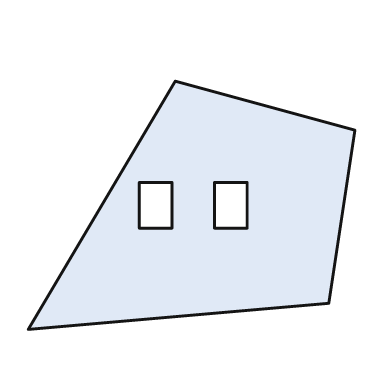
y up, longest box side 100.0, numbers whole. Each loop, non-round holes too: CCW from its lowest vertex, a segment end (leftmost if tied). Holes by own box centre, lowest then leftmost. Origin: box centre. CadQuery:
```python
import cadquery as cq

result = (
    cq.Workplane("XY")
    .moveTo(-50.0, -38.0)
    .lineTo(42.0, -30.0)
    .lineTo(50.0, 23.0)
    .lineTo(-5.0, 38.0)
    .close()
    .moveTo(-16.0, -7.0)
    .lineTo(-6.0, -7.0)
    .lineTo(-6.0, 7.0)
    .lineTo(-16.0, 7.0)
    .close()
    .moveTo(7.0, -7.0)
    .lineTo(17.0, -7.0)
    .lineTo(17.0, 7.0)
    .lineTo(7.0, 7.0)
    .close()
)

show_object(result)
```